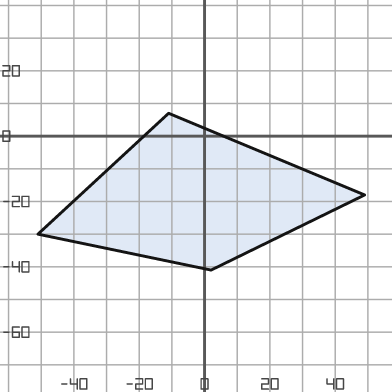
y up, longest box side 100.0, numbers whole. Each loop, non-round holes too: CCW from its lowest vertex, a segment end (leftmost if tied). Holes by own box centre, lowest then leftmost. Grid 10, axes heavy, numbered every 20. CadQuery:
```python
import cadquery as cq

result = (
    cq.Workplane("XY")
    .moveTo(2.0, -41.0)
    .lineTo(49.0, -18.0)
    .lineTo(-11.0, 7.0)
    .lineTo(-51.0, -30.0)
    .close()
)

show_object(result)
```